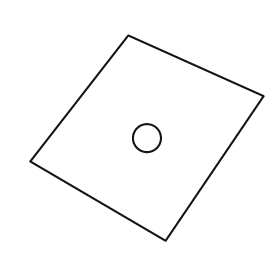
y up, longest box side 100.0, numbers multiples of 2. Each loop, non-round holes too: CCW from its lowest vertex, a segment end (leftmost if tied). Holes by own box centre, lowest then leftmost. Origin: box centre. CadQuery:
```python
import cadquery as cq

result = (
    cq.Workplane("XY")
    .moveTo(8.0, -44.0)
    .lineTo(50.0, 18.0)
    .lineTo(-8.0, 44.0)
    .lineTo(-50.0, -10.0)
    .close()
    .moveTo(0.0, 0.0)
    .circle(6.0)
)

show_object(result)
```